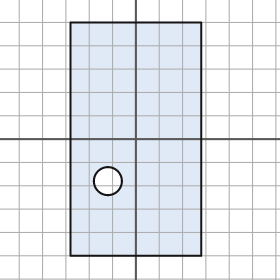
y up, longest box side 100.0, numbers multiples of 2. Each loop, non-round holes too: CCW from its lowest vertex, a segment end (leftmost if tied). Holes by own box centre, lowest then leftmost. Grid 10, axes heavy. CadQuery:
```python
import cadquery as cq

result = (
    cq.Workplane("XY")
    .moveTo(-28.0, -50.0)
    .lineTo(28.0, -50.0)
    .lineTo(28.0, 50.0)
    .lineTo(-28.0, 50.0)
    .close()
    .moveTo(-12.0, -18.0)
    .circle(6.0)
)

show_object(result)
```